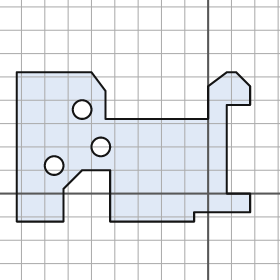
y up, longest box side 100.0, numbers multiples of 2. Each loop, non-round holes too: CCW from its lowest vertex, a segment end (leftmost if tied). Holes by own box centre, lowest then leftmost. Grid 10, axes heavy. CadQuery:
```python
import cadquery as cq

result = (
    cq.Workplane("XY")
    .moveTo(-82.0, -12.0)
    .lineTo(-62.0, -12.0)
    .lineTo(-62.0, 2.0)
    .lineTo(-54.0, 10.0)
    .lineTo(-42.0, 10.0)
    .lineTo(-42.0, -12.0)
    .lineTo(-6.0, -12.0)
    .lineTo(-6.0, -8.0)
    .lineTo(18.0, -8.0)
    .lineTo(18.0, 0.0)
    .lineTo(8.0, 0.0)
    .lineTo(8.0, 38.0)
    .lineTo(18.0, 38.0)
    .lineTo(18.0, 46.0)
    .lineTo(12.0, 52.0)
    .lineTo(8.0, 52.0)
    .lineTo(0.0, 46.0)
    .lineTo(0.0, 32.0)
    .lineTo(-44.0, 32.0)
    .lineTo(-44.0, 44.0)
    .lineTo(-50.0, 52.0)
    .lineTo(-82.0, 52.0)
    .close()
    .moveTo(-66.0, 12.0)
    .circle(4.0)
    .moveTo(-46.0, 20.0)
    .circle(4.0)
    .moveTo(-54.0, 36.0)
    .circle(4.0)
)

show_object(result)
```